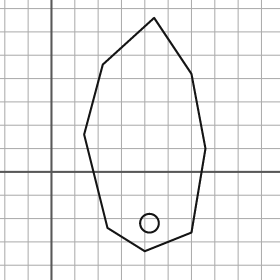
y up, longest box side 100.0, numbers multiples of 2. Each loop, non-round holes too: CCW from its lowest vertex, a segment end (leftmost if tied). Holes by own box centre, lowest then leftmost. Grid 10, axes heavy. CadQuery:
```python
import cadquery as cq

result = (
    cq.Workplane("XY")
    .moveTo(40.0, -34.0)
    .lineTo(60.0, -26.0)
    .lineTo(66.0, 10.0)
    .lineTo(60.0, 42.0)
    .lineTo(44.0, 66.0)
    .lineTo(22.0, 46.0)
    .lineTo(14.0, 16.0)
    .lineTo(24.0, -24.0)
    .close()
    .moveTo(42.0, -22.0)
    .circle(4.0)
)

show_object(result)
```